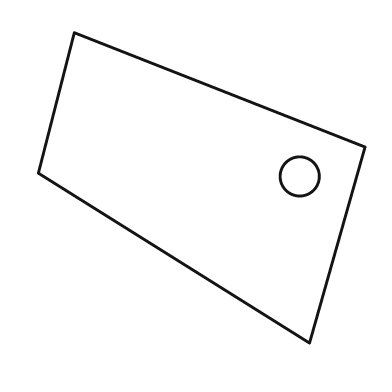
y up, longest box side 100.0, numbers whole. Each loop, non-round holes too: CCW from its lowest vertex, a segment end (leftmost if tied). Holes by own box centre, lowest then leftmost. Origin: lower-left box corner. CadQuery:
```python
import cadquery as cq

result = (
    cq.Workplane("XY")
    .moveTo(83.0, 0.0)
    .lineTo(100.0, 60.0)
    .lineTo(11.0, 95.0)
    .lineTo(0.0, 52.0)
    .close()
    .moveTo(80.0, 51.0)
    .circle(6.0)
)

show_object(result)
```